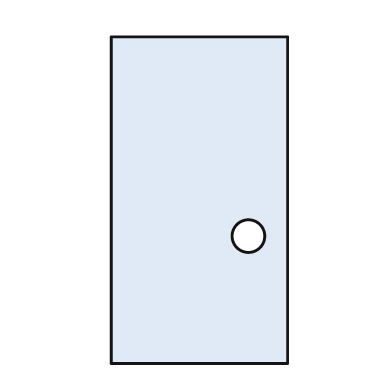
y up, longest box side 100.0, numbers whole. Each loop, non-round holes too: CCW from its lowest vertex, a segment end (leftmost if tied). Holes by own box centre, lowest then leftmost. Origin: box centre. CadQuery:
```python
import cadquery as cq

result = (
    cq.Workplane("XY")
    .moveTo(-27.0, -50.0)
    .lineTo(27.0, -50.0)
    .lineTo(27.0, 50.0)
    .lineTo(-27.0, 50.0)
    .close()
    .moveTo(15.0, -11.0)
    .circle(5.0)
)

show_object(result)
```